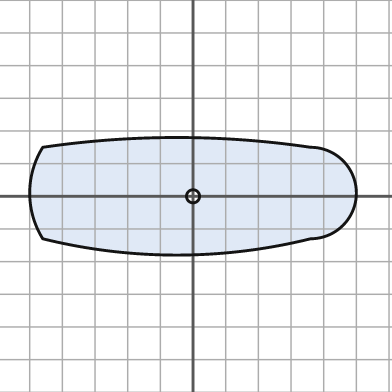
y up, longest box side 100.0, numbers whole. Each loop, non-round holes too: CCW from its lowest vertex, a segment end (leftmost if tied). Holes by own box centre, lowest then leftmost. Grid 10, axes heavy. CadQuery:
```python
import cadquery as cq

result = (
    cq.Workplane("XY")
    .moveTo(-46.0, -13.0)
    .threePointArc((-5.0, -18.0), (36.0, -13.0))
    .threePointArc((50.0, 1.0), (36.0, 15.0))
    .threePointArc((-5.0, 18.0), (-46.0, 15.0))
    .threePointArc((-50.0, 1.0), (-46.0, -13.0))
    .close()
    .moveTo(0.0, 0.0)
    .circle(2.0)
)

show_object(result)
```